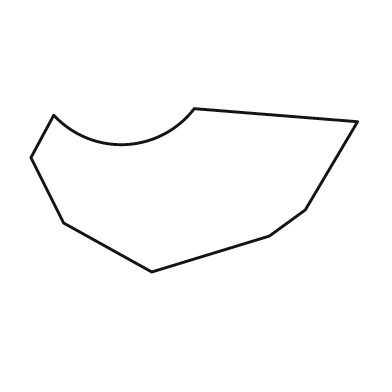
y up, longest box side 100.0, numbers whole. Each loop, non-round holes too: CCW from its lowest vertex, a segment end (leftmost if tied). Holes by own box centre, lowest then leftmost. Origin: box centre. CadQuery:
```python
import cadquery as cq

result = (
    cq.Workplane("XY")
    .moveTo(-13.0, -25.0)
    .lineTo(23.0, -14.0)
    .lineTo(34.0, -6.0)
    .lineTo(50.0, 21.0)
    .lineTo(0.0, 25.0)
    .threePointArc((-21.0, 14.0), (-43.0, 23.0))
    .lineTo(-50.0, 10.0)
    .lineTo(-40.0, -10.0)
    .close()
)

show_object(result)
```